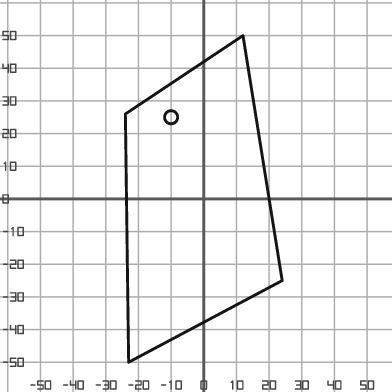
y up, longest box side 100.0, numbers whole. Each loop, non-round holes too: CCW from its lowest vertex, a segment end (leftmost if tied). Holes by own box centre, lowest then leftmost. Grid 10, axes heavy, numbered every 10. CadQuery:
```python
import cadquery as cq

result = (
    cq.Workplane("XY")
    .moveTo(-23.0, -50.0)
    .lineTo(24.0, -25.0)
    .lineTo(12.0, 50.0)
    .lineTo(-24.0, 26.0)
    .close()
    .moveTo(-10.0, 25.0)
    .circle(2.0)
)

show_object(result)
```